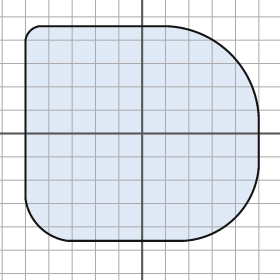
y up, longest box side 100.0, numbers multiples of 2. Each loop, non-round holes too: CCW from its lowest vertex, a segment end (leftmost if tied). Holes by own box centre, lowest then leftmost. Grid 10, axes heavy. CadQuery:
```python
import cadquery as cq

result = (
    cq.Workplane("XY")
    .moveTo(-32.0, -46.0)
    .lineTo(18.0, -46.0)
    .threePointArc((40.0, -36.0), (50.0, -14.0))
    .lineTo(50.0, 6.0)
    .threePointArc((38.0, 34.0), (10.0, 46.0))
    .lineTo(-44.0, 46.0)
    .threePointArc((-48.0, 44.0), (-50.0, 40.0))
    .lineTo(-50.0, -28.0)
    .threePointArc((-44.0, -40.0), (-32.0, -46.0))
    .close()
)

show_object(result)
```